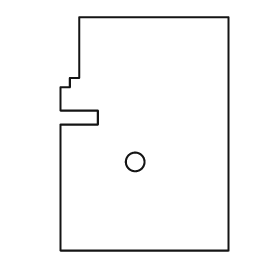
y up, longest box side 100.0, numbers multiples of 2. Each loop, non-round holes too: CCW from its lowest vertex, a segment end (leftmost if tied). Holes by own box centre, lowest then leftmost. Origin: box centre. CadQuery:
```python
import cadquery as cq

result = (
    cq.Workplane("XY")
    .moveTo(-36.0, -50.0)
    .lineTo(36.0, -50.0)
    .lineTo(36.0, 50.0)
    .lineTo(-28.0, 50.0)
    .lineTo(-28.0, 24.0)
    .lineTo(-32.0, 24.0)
    .lineTo(-32.0, 20.0)
    .lineTo(-36.0, 20.0)
    .lineTo(-36.0, 10.0)
    .lineTo(-20.0, 10.0)
    .lineTo(-20.0, 4.0)
    .lineTo(-36.0, 4.0)
    .close()
    .moveTo(-4.0, -12.0)
    .circle(4.0)
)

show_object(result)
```